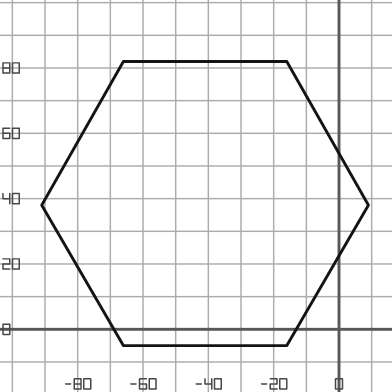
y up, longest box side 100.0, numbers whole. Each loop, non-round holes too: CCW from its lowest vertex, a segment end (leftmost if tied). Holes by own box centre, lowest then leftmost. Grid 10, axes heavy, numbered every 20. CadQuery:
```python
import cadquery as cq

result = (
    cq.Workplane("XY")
    .moveTo(-66.0, -5.0)
    .lineTo(-16.0, -5.0)
    .lineTo(9.0, 38.0)
    .lineTo(-16.0, 82.0)
    .lineTo(-66.0, 82.0)
    .lineTo(-91.0, 38.0)
    .close()
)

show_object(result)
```